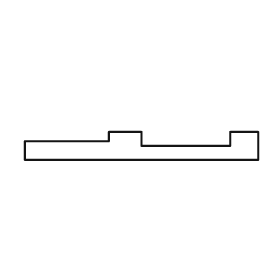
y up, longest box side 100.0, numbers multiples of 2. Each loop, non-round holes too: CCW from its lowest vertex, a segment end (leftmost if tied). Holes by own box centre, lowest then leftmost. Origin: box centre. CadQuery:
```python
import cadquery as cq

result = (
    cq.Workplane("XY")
    .moveTo(-50.0, -6.0)
    .lineTo(50.0, -6.0)
    .lineTo(50.0, 6.0)
    .lineTo(38.0, 6.0)
    .lineTo(38.0, 0.0)
    .lineTo(0.0, 0.0)
    .lineTo(0.0, 6.0)
    .lineTo(-14.0, 6.0)
    .lineTo(-14.0, 2.0)
    .lineTo(-50.0, 2.0)
    .close()
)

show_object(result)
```